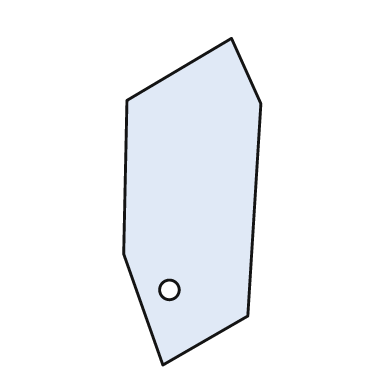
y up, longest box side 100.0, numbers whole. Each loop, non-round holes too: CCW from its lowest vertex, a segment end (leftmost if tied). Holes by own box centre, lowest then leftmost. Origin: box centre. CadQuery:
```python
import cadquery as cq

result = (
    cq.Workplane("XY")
    .moveTo(-9.0, -50.0)
    .lineTo(17.0, -35.0)
    .lineTo(21.0, 30.0)
    .lineTo(12.0, 50.0)
    .lineTo(-20.0, 31.0)
    .lineTo(-21.0, -16.0)
    .close()
    .moveTo(-7.0, -27.0)
    .circle(3.0)
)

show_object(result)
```